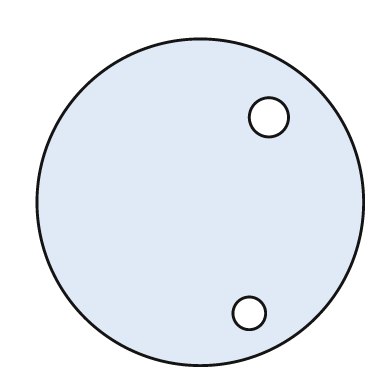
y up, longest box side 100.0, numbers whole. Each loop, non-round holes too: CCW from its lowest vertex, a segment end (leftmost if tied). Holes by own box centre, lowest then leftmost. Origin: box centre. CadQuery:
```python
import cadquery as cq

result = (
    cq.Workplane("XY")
    .moveTo(0.0, 0.0)
    .circle(50.0)
    .moveTo(15.0, -34.0)
    .circle(5.0)
    .moveTo(21.0, 26.0)
    .circle(6.0)
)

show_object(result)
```